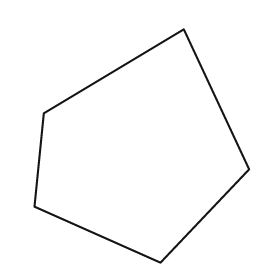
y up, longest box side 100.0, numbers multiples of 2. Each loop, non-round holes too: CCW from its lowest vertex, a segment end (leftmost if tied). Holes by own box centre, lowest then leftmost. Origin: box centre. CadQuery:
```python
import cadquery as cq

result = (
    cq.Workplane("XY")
    .moveTo(8.0, -50.0)
    .lineTo(46.0, -10.0)
    .lineTo(18.0, 50.0)
    .lineTo(-42.0, 14.0)
    .lineTo(-46.0, -26.0)
    .close()
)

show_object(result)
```